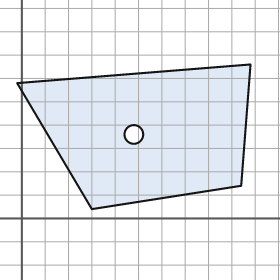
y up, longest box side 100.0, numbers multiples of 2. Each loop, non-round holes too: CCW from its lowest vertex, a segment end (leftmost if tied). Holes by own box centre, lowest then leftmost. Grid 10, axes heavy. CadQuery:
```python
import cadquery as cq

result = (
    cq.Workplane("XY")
    .moveTo(30.0, 4.0)
    .lineTo(94.0, 14.0)
    .lineTo(98.0, 66.0)
    .lineTo(-2.0, 58.0)
    .close()
    .moveTo(48.0, 36.0)
    .circle(4.0)
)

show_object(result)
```